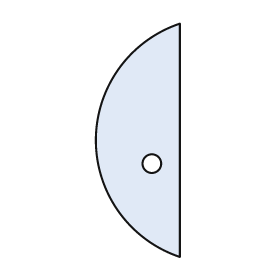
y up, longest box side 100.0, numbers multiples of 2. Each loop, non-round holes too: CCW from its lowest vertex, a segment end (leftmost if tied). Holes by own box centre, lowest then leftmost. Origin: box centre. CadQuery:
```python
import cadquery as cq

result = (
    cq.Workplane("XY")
    .moveTo(18.0, -50.0)
    .lineTo(18.0, 50.0)
    .threePointArc((-18.0, 0.0), (18.0, -50.0))
    .close()
    .moveTo(6.0, -10.0)
    .circle(4.0)
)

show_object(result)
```